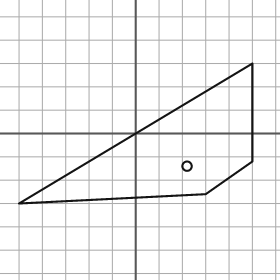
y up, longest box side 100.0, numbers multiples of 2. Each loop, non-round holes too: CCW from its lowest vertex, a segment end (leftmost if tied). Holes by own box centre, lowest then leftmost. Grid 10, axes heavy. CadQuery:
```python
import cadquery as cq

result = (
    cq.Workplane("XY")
    .moveTo(-50.0, -30.0)
    .lineTo(30.0, -26.0)
    .lineTo(50.0, -12.0)
    .lineTo(50.0, 30.0)
    .close()
    .moveTo(22.0, -14.0)
    .circle(2.0)
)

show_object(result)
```